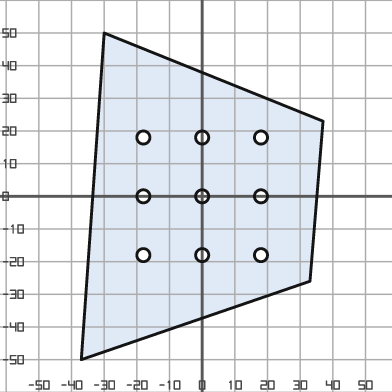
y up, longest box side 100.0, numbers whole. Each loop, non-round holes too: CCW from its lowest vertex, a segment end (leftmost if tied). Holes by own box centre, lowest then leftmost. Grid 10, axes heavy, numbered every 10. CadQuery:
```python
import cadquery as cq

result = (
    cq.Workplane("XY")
    .moveTo(-37.0, -50.0)
    .lineTo(33.0, -26.0)
    .lineTo(37.0, 23.0)
    .lineTo(-30.0, 50.0)
    .close()
    .moveTo(-18.0, -18.0)
    .circle(2.0)
    .moveTo(0.0, -18.0)
    .circle(2.0)
    .moveTo(18.0, -18.0)
    .circle(2.0)
    .moveTo(-18.0, 0.0)
    .circle(2.0)
    .moveTo(0.0, 0.0)
    .circle(2.0)
    .moveTo(18.0, 0.0)
    .circle(2.0)
    .moveTo(-18.0, 18.0)
    .circle(2.0)
    .moveTo(0.0, 18.0)
    .circle(2.0)
    .moveTo(18.0, 18.0)
    .circle(2.0)
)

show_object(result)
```